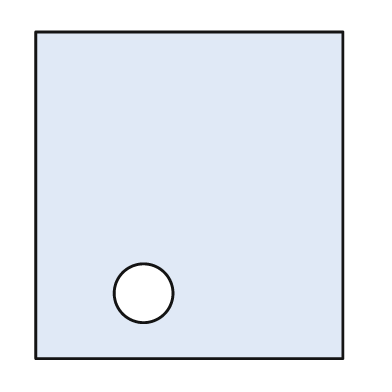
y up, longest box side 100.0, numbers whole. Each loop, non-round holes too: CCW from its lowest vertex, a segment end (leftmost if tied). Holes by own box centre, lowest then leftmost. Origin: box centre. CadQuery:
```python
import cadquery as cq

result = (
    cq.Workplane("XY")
    .moveTo(-47.0, -50.0)
    .lineTo(47.0, -50.0)
    .lineTo(47.0, 50.0)
    .lineTo(-47.0, 50.0)
    .close()
    .moveTo(-14.0, -30.0)
    .circle(9.0)
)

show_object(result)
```